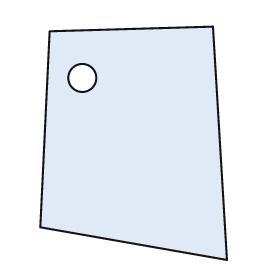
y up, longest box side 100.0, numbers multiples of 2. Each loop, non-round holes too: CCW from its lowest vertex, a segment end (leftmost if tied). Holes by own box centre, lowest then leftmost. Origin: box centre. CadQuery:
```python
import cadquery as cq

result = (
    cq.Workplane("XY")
    .moveTo(40.0, -50.0)
    .lineTo(34.0, 50.0)
    .lineTo(-36.0, 48.0)
    .lineTo(-40.0, -36.0)
    .close()
    .moveTo(-22.0, 28.0)
    .circle(6.0)
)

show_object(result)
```